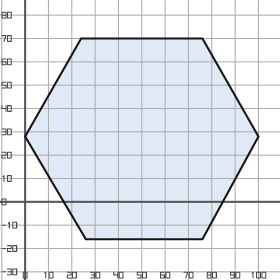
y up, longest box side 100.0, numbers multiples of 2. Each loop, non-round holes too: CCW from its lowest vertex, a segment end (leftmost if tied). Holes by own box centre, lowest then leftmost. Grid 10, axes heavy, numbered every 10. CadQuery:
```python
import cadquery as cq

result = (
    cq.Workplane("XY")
    .moveTo(26.0, -16.0)
    .lineTo(76.0, -16.0)
    .lineTo(100.0, 28.0)
    .lineTo(76.0, 70.0)
    .lineTo(24.0, 70.0)
    .lineTo(0.0, 28.0)
    .close()
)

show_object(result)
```